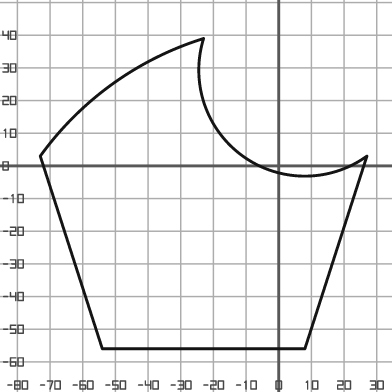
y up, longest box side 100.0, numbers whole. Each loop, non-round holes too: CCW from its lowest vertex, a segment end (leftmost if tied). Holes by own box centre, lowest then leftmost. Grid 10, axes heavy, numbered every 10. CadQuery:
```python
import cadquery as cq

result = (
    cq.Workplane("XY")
    .moveTo(-54.0, -56.0)
    .lineTo(8.0, -56.0)
    .lineTo(27.0, 3.0)
    .threePointArc((-11.0, 3.0), (-23.0, 39.0))
    .threePointArc((-51.0, 25.0), (-73.0, 3.0))
    .close()
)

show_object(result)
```